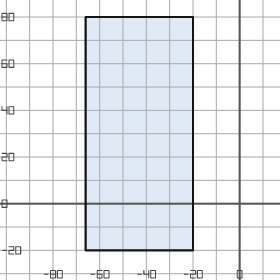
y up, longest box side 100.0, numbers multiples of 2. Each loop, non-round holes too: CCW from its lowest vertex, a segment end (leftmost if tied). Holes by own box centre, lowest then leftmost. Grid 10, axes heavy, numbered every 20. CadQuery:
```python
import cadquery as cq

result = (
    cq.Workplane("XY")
    .moveTo(-66.0, -20.0)
    .lineTo(-20.0, -20.0)
    .lineTo(-20.0, 80.0)
    .lineTo(-66.0, 80.0)
    .close()
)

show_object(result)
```